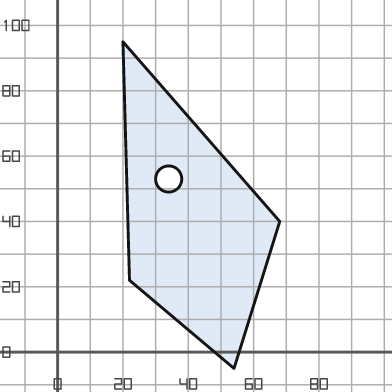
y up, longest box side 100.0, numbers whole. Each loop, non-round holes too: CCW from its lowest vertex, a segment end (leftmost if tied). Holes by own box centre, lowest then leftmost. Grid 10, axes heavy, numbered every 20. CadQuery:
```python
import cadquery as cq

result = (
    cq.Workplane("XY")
    .moveTo(54.0, -5.0)
    .lineTo(68.0, 40.0)
    .lineTo(20.0, 95.0)
    .lineTo(22.0, 22.0)
    .close()
    .moveTo(34.0, 53.0)
    .circle(4.0)
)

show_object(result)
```